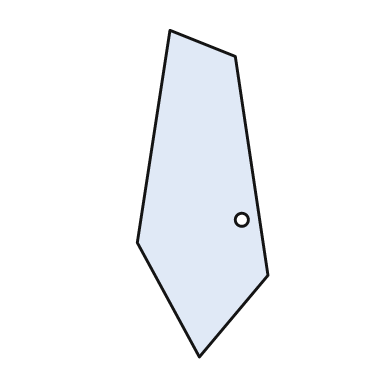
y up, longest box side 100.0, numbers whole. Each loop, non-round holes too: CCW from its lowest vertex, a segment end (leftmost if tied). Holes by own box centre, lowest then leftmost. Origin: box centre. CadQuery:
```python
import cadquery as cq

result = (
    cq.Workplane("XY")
    .moveTo(-1.0, -50.0)
    .lineTo(20.0, -25.0)
    .lineTo(10.0, 42.0)
    .lineTo(-10.0, 50.0)
    .lineTo(-20.0, -15.0)
    .close()
    .moveTo(12.0, -8.0)
    .circle(2.0)
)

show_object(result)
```